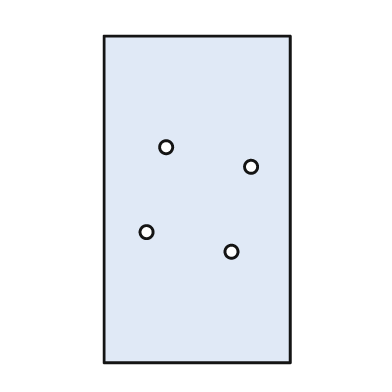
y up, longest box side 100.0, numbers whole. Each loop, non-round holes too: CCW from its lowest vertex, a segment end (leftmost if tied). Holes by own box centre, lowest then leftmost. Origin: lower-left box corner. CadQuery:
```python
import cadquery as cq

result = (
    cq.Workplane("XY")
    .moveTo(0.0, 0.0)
    .lineTo(57.0, 0.0)
    .lineTo(57.0, 100.0)
    .lineTo(0.0, 100.0)
    .close()
    .moveTo(39.0, 34.0)
    .circle(2.0)
    .moveTo(13.0, 40.0)
    .circle(2.0)
    .moveTo(45.0, 60.0)
    .circle(2.0)
    .moveTo(19.0, 66.0)
    .circle(2.0)
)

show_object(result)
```